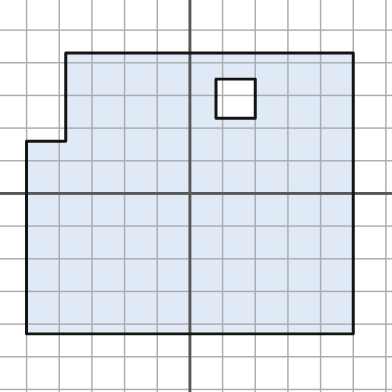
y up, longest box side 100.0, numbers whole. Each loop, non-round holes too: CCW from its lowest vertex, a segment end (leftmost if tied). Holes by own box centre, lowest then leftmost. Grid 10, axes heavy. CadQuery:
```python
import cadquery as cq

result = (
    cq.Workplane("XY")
    .moveTo(-50.0, -43.0)
    .lineTo(50.0, -43.0)
    .lineTo(50.0, 43.0)
    .lineTo(-38.0, 43.0)
    .lineTo(-38.0, 16.0)
    .lineTo(-50.0, 16.0)
    .close()
    .moveTo(8.0, 23.0)
    .lineTo(20.0, 23.0)
    .lineTo(20.0, 35.0)
    .lineTo(8.0, 35.0)
    .close()
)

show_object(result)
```